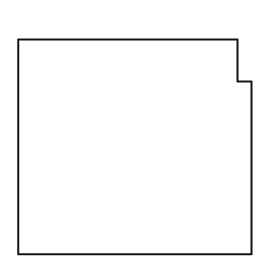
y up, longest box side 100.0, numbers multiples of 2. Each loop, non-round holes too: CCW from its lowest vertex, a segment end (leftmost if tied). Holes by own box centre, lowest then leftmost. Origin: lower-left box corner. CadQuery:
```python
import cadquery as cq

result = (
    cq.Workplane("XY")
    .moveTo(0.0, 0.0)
    .lineTo(100.0, 0.0)
    .lineTo(100.0, 74.0)
    .lineTo(94.0, 74.0)
    .lineTo(94.0, 92.0)
    .lineTo(0.0, 92.0)
    .close()
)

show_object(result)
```